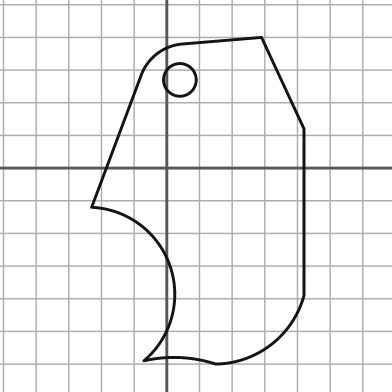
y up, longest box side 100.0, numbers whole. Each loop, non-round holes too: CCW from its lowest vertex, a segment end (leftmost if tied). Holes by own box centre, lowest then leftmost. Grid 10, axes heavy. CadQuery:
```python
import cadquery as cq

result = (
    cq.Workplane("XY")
    .moveTo(15.0, -60.0)
    .threePointArc((32.0, -54.0), (42.0, -39.0))
    .lineTo(42.0, 12.0)
    .lineTo(29.0, 40.0)
    .lineTo(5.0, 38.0)
    .threePointArc((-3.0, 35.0), (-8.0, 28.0))
    .lineTo(-23.0, -12.0)
    .threePointArc((1.0, -30.0), (-7.0, -59.0))
    .threePointArc((4.0, -58.0), (15.0, -60.0))
    .close()
    .moveTo(4.0, 27.0)
    .circle(5.0)
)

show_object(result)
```